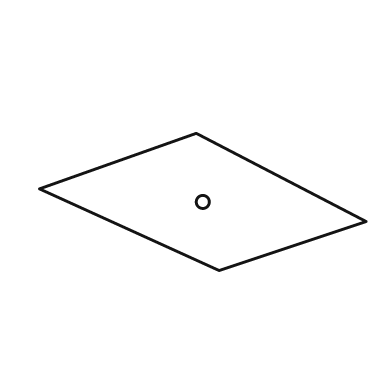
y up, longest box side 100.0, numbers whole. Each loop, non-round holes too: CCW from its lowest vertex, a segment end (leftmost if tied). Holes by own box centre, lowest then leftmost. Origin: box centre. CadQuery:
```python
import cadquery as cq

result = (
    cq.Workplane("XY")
    .moveTo(5.0, -21.0)
    .lineTo(50.0, -6.0)
    .lineTo(-2.0, 21.0)
    .lineTo(-50.0, 4.0)
    .close()
    .moveTo(0.0, 0.0)
    .circle(2.0)
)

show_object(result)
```